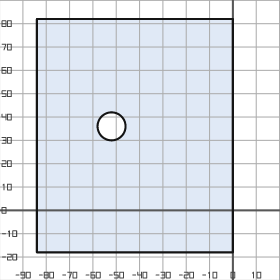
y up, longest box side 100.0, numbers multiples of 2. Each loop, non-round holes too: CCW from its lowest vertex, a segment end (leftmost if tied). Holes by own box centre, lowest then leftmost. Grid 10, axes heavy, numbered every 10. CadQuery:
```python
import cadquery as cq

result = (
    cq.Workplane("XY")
    .moveTo(-84.0, -18.0)
    .lineTo(0.0, -18.0)
    .lineTo(0.0, 82.0)
    .lineTo(-84.0, 82.0)
    .close()
    .moveTo(-52.0, 36.0)
    .circle(6.0)
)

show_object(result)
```